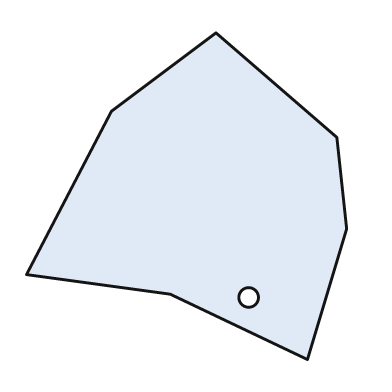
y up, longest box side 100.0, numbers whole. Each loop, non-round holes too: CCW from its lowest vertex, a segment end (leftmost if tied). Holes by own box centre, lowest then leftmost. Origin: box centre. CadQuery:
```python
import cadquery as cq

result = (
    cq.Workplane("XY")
    .moveTo(37.0, -50.0)
    .lineTo(49.0, -10.0)
    .lineTo(46.0, 18.0)
    .lineTo(9.0, 50.0)
    .lineTo(-23.0, 26.0)
    .lineTo(-49.0, -24.0)
    .lineTo(-5.0, -30.0)
    .close()
    .moveTo(19.0, -31.0)
    .circle(3.0)
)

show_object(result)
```